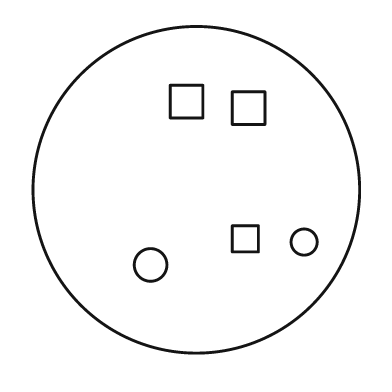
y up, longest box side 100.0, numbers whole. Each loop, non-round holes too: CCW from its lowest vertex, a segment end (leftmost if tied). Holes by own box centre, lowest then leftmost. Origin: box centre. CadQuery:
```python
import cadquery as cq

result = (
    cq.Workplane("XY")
    .moveTo(0.0, 0.0)
    .circle(50.0)
    .moveTo(-14.0, -23.0)
    .circle(5.0)
    .moveTo(33.0, -16.0)
    .circle(4.0)
    .moveTo(11.0, -19.0)
    .lineTo(19.0, -19.0)
    .lineTo(19.0, -11.0)
    .lineTo(11.0, -11.0)
    .close()
    .moveTo(11.0, 20.0)
    .lineTo(21.0, 20.0)
    .lineTo(21.0, 30.0)
    .lineTo(11.0, 30.0)
    .close()
    .moveTo(-8.0, 22.0)
    .lineTo(2.0, 22.0)
    .lineTo(2.0, 32.0)
    .lineTo(-8.0, 32.0)
    .close()
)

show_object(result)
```